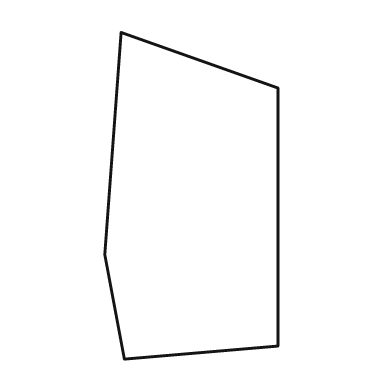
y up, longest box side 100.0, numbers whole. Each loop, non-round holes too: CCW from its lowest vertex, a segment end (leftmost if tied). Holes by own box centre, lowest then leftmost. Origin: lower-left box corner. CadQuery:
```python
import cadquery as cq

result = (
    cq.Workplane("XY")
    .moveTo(6.0, 0.0)
    .lineTo(53.0, 4.0)
    .lineTo(53.0, 83.0)
    .lineTo(5.0, 100.0)
    .lineTo(0.0, 32.0)
    .close()
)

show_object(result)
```